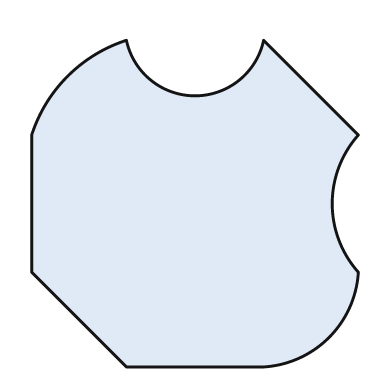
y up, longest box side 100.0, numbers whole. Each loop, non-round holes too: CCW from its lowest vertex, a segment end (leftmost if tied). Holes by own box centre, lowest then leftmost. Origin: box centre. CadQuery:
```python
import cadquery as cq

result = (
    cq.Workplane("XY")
    .moveTo(-21.0, -50.0)
    .lineTo(21.0, -50.0)
    .threePointArc((41.0, -41.0), (50.0, -21.0))
    .threePointArc((42.0, 0.0), (50.0, 21.0))
    .lineTo(21.0, 50.0)
    .threePointArc((0.0, 33.0), (-21.0, 50.0))
    .threePointArc((-39.0, 39.0), (-50.0, 21.0))
    .lineTo(-50.0, -21.0)
    .close()
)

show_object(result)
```